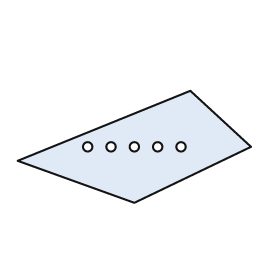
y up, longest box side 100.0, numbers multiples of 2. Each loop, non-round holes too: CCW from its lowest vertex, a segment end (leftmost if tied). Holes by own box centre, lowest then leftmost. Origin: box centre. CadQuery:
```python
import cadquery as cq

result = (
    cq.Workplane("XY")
    .moveTo(0.0, -24.0)
    .lineTo(50.0, 0.0)
    .lineTo(24.0, 24.0)
    .lineTo(-50.0, -6.0)
    .close()
    .moveTo(-20.0, 0.0)
    .circle(2.0)
    .moveTo(-10.0, 0.0)
    .circle(2.0)
    .moveTo(0.0, 0.0)
    .circle(2.0)
    .moveTo(10.0, 0.0)
    .circle(2.0)
    .moveTo(20.0, 0.0)
    .circle(2.0)
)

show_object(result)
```